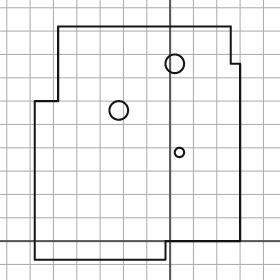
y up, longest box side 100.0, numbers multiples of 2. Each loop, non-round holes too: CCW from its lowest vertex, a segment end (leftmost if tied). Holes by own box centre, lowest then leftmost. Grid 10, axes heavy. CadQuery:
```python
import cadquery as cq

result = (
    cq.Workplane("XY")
    .moveTo(-58.0, -8.0)
    .lineTo(-2.0, -8.0)
    .lineTo(-2.0, 0.0)
    .lineTo(30.0, 0.0)
    .lineTo(30.0, 76.0)
    .lineTo(26.0, 76.0)
    .lineTo(26.0, 92.0)
    .lineTo(-48.0, 92.0)
    .lineTo(-48.0, 60.0)
    .lineTo(-58.0, 60.0)
    .close()
    .moveTo(4.0, 38.0)
    .circle(2.0)
    .moveTo(-22.0, 56.0)
    .circle(4.0)
    .moveTo(2.0, 76.0)
    .circle(4.0)
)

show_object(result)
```